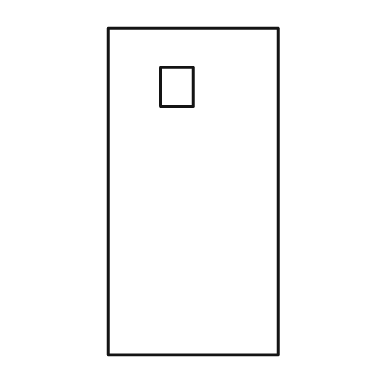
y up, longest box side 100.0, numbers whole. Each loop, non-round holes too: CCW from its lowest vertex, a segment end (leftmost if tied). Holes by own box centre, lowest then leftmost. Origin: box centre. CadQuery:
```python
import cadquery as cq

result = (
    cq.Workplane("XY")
    .moveTo(-26.0, -50.0)
    .lineTo(26.0, -50.0)
    .lineTo(26.0, 50.0)
    .lineTo(-26.0, 50.0)
    .close()
    .moveTo(-10.0, 26.0)
    .lineTo(0.0, 26.0)
    .lineTo(0.0, 38.0)
    .lineTo(-10.0, 38.0)
    .close()
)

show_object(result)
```